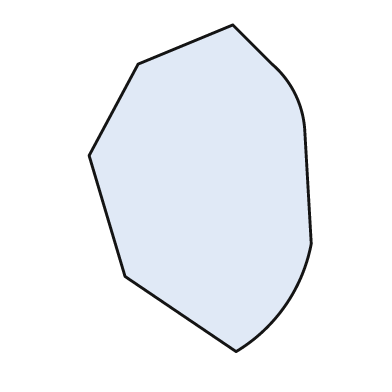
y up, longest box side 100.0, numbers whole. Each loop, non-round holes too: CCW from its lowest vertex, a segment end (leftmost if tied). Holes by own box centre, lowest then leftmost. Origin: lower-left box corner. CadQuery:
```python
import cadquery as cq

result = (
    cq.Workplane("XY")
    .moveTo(45.0, 0.0)
    .threePointArc((60.0, 14.0), (68.0, 33.0))
    .lineTo(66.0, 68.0)
    .threePointArc((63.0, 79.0), (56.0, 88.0))
    .lineTo(44.0, 100.0)
    .lineTo(15.0, 88.0)
    .lineTo(0.0, 60.0)
    .lineTo(11.0, 23.0)
    .close()
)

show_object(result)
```